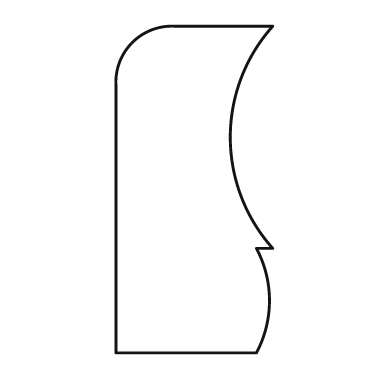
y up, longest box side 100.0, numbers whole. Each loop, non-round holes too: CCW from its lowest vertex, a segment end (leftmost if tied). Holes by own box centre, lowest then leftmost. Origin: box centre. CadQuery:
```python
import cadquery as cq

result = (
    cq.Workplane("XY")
    .moveTo(-24.0, -50.0)
    .lineTo(19.0, -50.0)
    .threePointArc((23.0, -34.0), (19.0, -18.0))
    .lineTo(24.0, -18.0)
    .threePointArc((11.0, 16.0), (24.0, 50.0))
    .lineTo(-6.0, 50.0)
    .threePointArc((-19.0, 45.0), (-24.0, 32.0))
    .close()
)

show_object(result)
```